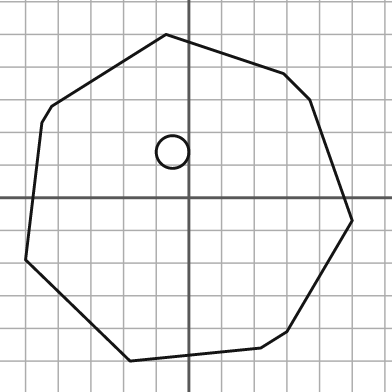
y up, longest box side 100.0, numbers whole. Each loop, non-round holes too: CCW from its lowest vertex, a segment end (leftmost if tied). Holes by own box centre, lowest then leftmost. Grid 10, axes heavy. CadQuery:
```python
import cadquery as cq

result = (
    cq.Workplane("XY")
    .moveTo(-18.0, -50.0)
    .lineTo(22.0, -46.0)
    .lineTo(30.0, -41.0)
    .lineTo(50.0, -7.0)
    .lineTo(37.0, 30.0)
    .lineTo(29.0, 38.0)
    .lineTo(-7.0, 50.0)
    .lineTo(-42.0, 28.0)
    .lineTo(-45.0, 23.0)
    .lineTo(-50.0, -19.0)
    .close()
    .moveTo(-5.0, 14.0)
    .circle(5.0)
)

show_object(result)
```